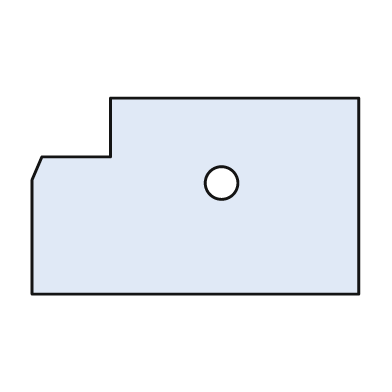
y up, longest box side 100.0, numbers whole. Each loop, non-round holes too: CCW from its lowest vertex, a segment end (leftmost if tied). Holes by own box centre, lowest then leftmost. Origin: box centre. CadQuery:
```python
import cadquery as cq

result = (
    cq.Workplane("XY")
    .moveTo(-50.0, -30.0)
    .lineTo(50.0, -30.0)
    .lineTo(50.0, 30.0)
    .lineTo(-26.0, 30.0)
    .lineTo(-26.0, 12.0)
    .lineTo(-47.0, 12.0)
    .lineTo(-50.0, 5.0)
    .close()
    .moveTo(8.0, 4.0)
    .circle(5.0)
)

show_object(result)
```